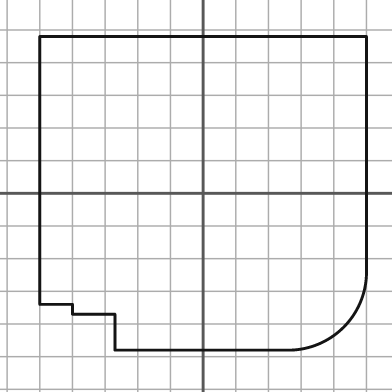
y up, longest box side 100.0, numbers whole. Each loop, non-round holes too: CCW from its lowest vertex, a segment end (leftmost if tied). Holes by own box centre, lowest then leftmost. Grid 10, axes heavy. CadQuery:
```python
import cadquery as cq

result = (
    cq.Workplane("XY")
    .moveTo(-27.0, -48.0)
    .lineTo(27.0, -48.0)
    .threePointArc((43.0, -41.0), (50.0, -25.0))
    .lineTo(50.0, 48.0)
    .lineTo(-50.0, 48.0)
    .lineTo(-50.0, -34.0)
    .lineTo(-40.0, -34.0)
    .lineTo(-40.0, -37.0)
    .lineTo(-27.0, -37.0)
    .close()
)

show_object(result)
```